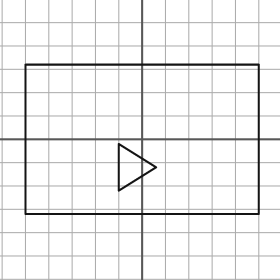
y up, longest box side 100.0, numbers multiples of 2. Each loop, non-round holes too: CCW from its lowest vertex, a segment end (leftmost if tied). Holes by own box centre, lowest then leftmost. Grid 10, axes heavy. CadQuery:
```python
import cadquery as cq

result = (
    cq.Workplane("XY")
    .moveTo(-50.0, -32.0)
    .lineTo(50.0, -32.0)
    .lineTo(50.0, 32.0)
    .lineTo(-50.0, 32.0)
    .close()
    .moveTo(-10.0, -22.0)
    .lineTo(6.0, -12.0)
    .lineTo(-10.0, -2.0)
    .close()
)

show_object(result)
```